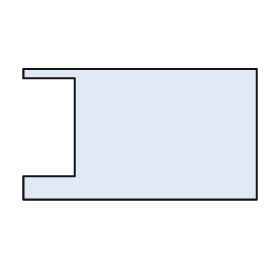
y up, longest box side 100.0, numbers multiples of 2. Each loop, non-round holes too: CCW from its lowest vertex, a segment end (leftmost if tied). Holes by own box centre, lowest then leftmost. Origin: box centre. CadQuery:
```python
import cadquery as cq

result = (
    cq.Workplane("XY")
    .moveTo(-50.0, -28.0)
    .lineTo(50.0, -28.0)
    .lineTo(50.0, 28.0)
    .lineTo(-50.0, 28.0)
    .lineTo(-50.0, 24.0)
    .lineTo(-28.0, 24.0)
    .lineTo(-28.0, -18.0)
    .lineTo(-50.0, -18.0)
    .close()
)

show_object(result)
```